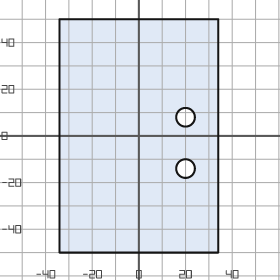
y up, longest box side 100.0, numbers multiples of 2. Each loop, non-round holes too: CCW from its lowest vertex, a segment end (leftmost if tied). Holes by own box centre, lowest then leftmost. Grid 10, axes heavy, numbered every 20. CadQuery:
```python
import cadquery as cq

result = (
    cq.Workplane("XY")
    .moveTo(-34.0, -50.0)
    .lineTo(34.0, -50.0)
    .lineTo(34.0, 50.0)
    .lineTo(-34.0, 50.0)
    .close()
    .moveTo(20.0, -14.0)
    .circle(4.0)
    .moveTo(20.0, 8.0)
    .circle(4.0)
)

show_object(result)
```